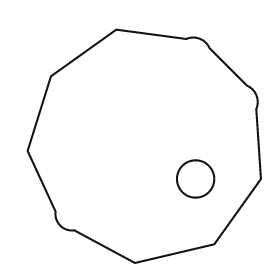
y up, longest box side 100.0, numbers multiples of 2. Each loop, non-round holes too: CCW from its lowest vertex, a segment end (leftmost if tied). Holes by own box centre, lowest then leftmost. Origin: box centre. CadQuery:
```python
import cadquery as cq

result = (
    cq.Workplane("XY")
    .moveTo(-4.0, -50.0)
    .lineTo(30.0, -42.0)
    .lineTo(50.0, -14.0)
    .lineTo(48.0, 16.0)
    .threePointArc((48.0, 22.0), (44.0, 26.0))
    .lineTo(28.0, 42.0)
    .threePointArc((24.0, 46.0), (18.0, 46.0))
    .lineTo(-12.0, 50.0)
    .lineTo(-40.0, 30.0)
    .lineTo(-50.0, -2.0)
    .lineTo(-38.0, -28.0)
    .threePointArc((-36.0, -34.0), (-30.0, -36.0))
    .close()
    .moveTo(22.0, -14.0)
    .circle(8.0)
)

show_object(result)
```